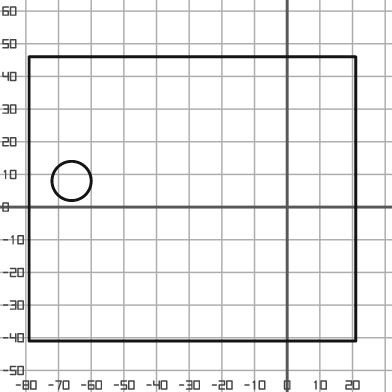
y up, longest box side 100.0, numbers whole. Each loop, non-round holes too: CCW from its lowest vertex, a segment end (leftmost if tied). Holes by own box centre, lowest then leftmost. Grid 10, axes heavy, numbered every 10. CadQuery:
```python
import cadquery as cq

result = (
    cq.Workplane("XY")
    .moveTo(-79.0, -41.0)
    .lineTo(21.0, -41.0)
    .lineTo(21.0, 46.0)
    .lineTo(-79.0, 46.0)
    .close()
    .moveTo(-66.0, 8.0)
    .circle(6.0)
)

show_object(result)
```